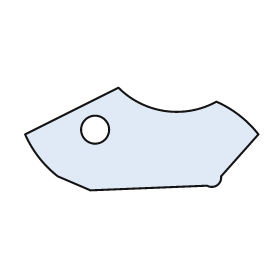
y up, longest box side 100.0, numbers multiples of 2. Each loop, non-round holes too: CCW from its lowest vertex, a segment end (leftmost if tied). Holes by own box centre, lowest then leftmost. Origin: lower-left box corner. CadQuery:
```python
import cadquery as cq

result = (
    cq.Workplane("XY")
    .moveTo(28.0, 0.0)
    .lineTo(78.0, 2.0)
    .threePointArc((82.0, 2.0), (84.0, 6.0))
    .lineTo(100.0, 24.0)
    .threePointArc((92.0, 32.0), (82.0, 38.0))
    .threePointArc((60.0, 34.0), (40.0, 44.0))
    .lineTo(0.0, 24.0)
    .threePointArc((6.0, 14.0), (14.0, 6.0))
    .close()
    .moveTo(30.0, 26.0)
    .circle(6.0)
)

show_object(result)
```